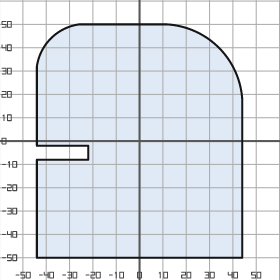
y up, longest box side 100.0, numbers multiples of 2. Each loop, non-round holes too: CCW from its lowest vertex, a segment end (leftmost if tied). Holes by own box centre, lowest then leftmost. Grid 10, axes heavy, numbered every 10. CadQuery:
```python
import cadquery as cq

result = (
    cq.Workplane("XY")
    .moveTo(-44.0, -50.0)
    .lineTo(44.0, -50.0)
    .lineTo(44.0, 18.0)
    .threePointArc((34.0, 40.0), (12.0, 50.0))
    .lineTo(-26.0, 50.0)
    .threePointArc((-38.0, 44.0), (-44.0, 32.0))
    .lineTo(-44.0, -2.0)
    .lineTo(-22.0, -2.0)
    .lineTo(-22.0, -8.0)
    .lineTo(-44.0, -8.0)
    .close()
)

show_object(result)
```